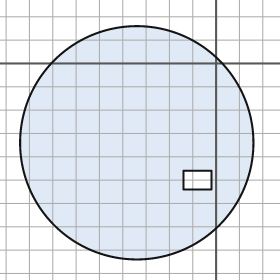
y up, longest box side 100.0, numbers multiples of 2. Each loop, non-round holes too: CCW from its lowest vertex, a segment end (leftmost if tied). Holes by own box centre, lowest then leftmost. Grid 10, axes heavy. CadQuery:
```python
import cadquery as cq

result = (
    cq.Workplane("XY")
    .moveTo(-34.0, -34.0)
    .circle(50.0)
    .moveTo(-14.0, -54.0)
    .lineTo(-2.0, -54.0)
    .lineTo(-2.0, -46.0)
    .lineTo(-14.0, -46.0)
    .close()
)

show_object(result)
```